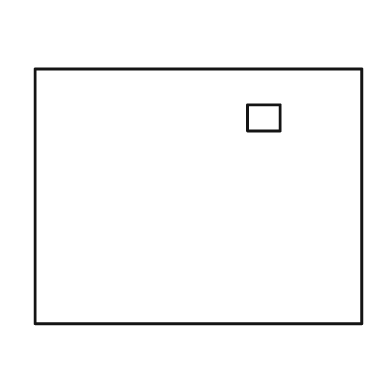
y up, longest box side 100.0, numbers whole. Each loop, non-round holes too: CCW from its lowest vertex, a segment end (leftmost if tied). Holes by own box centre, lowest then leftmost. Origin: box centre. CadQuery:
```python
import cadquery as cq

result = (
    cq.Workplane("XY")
    .moveTo(-50.0, -39.0)
    .lineTo(50.0, -39.0)
    .lineTo(50.0, 39.0)
    .lineTo(-50.0, 39.0)
    .close()
    .moveTo(15.0, 20.0)
    .lineTo(25.0, 20.0)
    .lineTo(25.0, 28.0)
    .lineTo(15.0, 28.0)
    .close()
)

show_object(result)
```